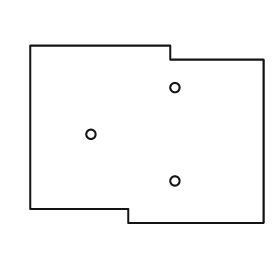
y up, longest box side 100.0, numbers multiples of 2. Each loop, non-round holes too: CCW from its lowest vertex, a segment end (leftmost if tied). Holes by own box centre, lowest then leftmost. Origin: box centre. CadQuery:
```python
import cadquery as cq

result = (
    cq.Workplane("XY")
    .moveTo(-8.0, -38.0)
    .lineTo(50.0, -38.0)
    .lineTo(50.0, 32.0)
    .lineTo(10.0, 32.0)
    .lineTo(10.0, 38.0)
    .lineTo(-50.0, 38.0)
    .lineTo(-50.0, -32.0)
    .lineTo(-8.0, -32.0)
    .close()
    .moveTo(12.0, -20.0)
    .circle(2.0)
    .moveTo(-24.0, 0.0)
    .circle(2.0)
    .moveTo(12.0, 20.0)
    .circle(2.0)
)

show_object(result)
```